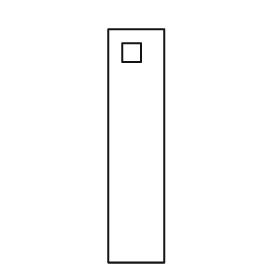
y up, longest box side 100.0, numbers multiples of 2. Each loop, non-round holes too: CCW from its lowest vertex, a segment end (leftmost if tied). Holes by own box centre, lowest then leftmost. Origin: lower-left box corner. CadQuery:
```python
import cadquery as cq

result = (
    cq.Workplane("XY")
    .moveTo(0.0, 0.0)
    .lineTo(24.0, 0.0)
    .lineTo(24.0, 100.0)
    .lineTo(0.0, 100.0)
    .close()
    .moveTo(6.0, 86.0)
    .lineTo(14.0, 86.0)
    .lineTo(14.0, 94.0)
    .lineTo(6.0, 94.0)
    .close()
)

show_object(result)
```